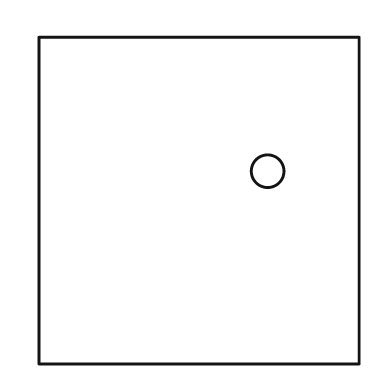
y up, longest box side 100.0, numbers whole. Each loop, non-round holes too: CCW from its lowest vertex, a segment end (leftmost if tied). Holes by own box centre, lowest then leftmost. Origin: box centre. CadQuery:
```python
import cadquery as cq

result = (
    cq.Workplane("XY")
    .moveTo(-49.0, -50.0)
    .lineTo(49.0, -50.0)
    .lineTo(49.0, 50.0)
    .lineTo(-49.0, 50.0)
    .close()
    .moveTo(21.0, 9.0)
    .circle(5.0)
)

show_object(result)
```